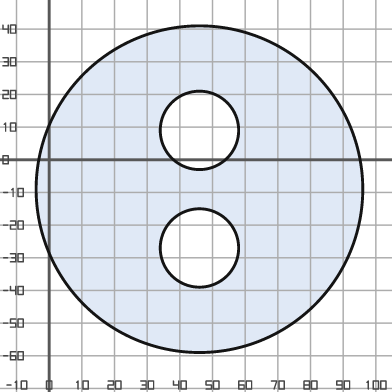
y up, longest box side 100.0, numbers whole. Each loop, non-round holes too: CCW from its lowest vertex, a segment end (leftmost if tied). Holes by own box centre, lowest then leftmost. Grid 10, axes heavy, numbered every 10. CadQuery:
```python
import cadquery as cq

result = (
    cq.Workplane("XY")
    .moveTo(46.0, -9.0)
    .circle(50.0)
    .moveTo(46.0, -27.0)
    .circle(12.0)
    .moveTo(46.0, 9.0)
    .circle(12.0)
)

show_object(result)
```